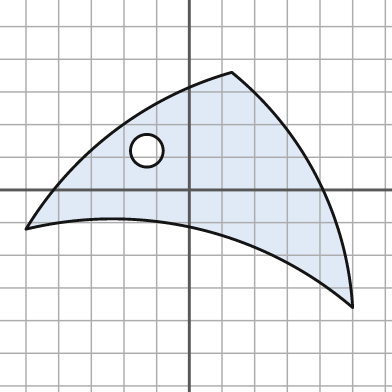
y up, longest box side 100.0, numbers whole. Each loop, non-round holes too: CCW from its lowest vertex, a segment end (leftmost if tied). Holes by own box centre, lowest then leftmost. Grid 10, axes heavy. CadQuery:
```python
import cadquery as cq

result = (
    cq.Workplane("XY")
    .moveTo(50.0, -36.0)
    .threePointArc((39.0, 4.0), (13.0, 36.0))
    .threePointArc((-23.0, 18.0), (-50.0, -12.0))
    .threePointArc((3.0, -12.0), (50.0, -36.0))
    .close()
    .moveTo(-13.0, 12.0)
    .circle(5.0)
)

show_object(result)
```